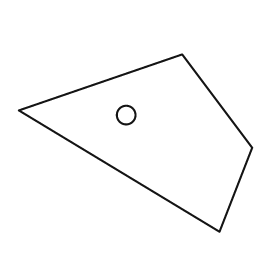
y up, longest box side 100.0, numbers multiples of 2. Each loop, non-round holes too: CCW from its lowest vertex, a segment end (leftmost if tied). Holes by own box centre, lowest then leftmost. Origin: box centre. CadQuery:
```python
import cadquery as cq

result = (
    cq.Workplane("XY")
    .moveTo(36.0, -38.0)
    .lineTo(50.0, -2.0)
    .lineTo(20.0, 38.0)
    .lineTo(-50.0, 14.0)
    .close()
    .moveTo(-4.0, 12.0)
    .circle(4.0)
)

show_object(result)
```